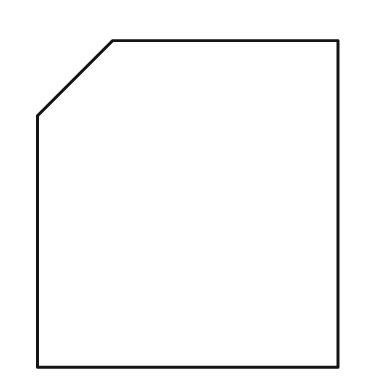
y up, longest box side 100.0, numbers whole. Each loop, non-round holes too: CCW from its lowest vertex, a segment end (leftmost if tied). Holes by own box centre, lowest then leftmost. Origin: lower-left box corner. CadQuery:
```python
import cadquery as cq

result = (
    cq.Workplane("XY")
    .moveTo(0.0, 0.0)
    .lineTo(92.0, 0.0)
    .lineTo(92.0, 100.0)
    .lineTo(23.0, 100.0)
    .lineTo(0.0, 77.0)
    .close()
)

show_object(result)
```